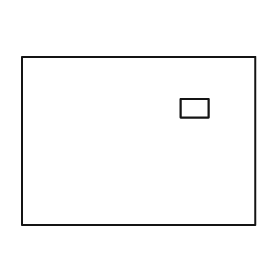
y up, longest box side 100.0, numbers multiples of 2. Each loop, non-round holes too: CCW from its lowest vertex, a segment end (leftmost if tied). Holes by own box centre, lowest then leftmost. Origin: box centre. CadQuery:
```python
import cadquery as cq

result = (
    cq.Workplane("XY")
    .moveTo(-50.0, -36.0)
    .lineTo(50.0, -36.0)
    .lineTo(50.0, 36.0)
    .lineTo(-50.0, 36.0)
    .close()
    .moveTo(18.0, 10.0)
    .lineTo(30.0, 10.0)
    .lineTo(30.0, 18.0)
    .lineTo(18.0, 18.0)
    .close()
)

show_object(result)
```